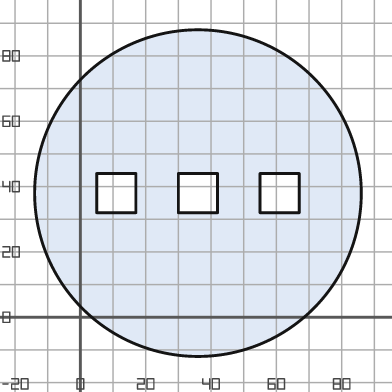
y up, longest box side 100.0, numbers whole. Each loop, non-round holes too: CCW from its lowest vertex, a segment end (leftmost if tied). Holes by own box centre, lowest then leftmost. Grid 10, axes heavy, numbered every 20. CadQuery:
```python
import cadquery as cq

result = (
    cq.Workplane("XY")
    .moveTo(36.0, 38.0)
    .circle(50.0)
    .moveTo(5.0, 32.0)
    .lineTo(17.0, 32.0)
    .lineTo(17.0, 44.0)
    .lineTo(5.0, 44.0)
    .close()
    .moveTo(30.0, 32.0)
    .lineTo(42.0, 32.0)
    .lineTo(42.0, 44.0)
    .lineTo(30.0, 44.0)
    .close()
    .moveTo(55.0, 32.0)
    .lineTo(67.0, 32.0)
    .lineTo(67.0, 44.0)
    .lineTo(55.0, 44.0)
    .close()
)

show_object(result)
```